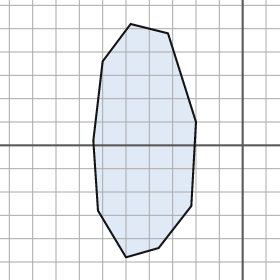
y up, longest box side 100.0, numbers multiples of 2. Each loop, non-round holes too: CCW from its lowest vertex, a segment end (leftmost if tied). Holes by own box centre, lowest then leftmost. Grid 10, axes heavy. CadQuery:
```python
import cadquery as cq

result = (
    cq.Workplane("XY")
    .moveTo(-50.0, -48.0)
    .lineTo(-36.0, -44.0)
    .lineTo(-22.0, -26.0)
    .lineTo(-20.0, 10.0)
    .lineTo(-32.0, 48.0)
    .lineTo(-48.0, 52.0)
    .lineTo(-60.0, 36.0)
    .lineTo(-64.0, 2.0)
    .lineTo(-62.0, -28.0)
    .close()
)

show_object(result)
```